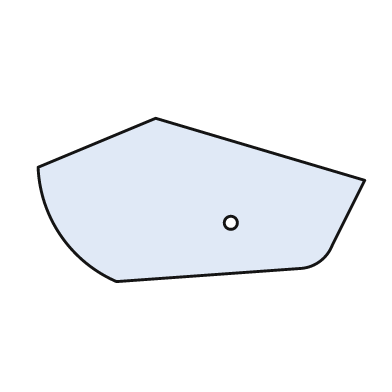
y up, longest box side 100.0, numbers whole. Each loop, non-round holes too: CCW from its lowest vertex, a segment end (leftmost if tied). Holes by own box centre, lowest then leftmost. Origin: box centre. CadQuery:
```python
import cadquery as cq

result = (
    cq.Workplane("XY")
    .moveTo(-26.0, -25.0)
    .lineTo(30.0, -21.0)
    .threePointArc((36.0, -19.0), (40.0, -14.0))
    .lineTo(50.0, 6.0)
    .lineTo(-14.0, 25.0)
    .lineTo(-50.0, 10.0)
    .threePointArc((-43.0, -11.0), (-26.0, -25.0))
    .close()
    .moveTo(9.0, -7.0)
    .circle(2.0)
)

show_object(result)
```